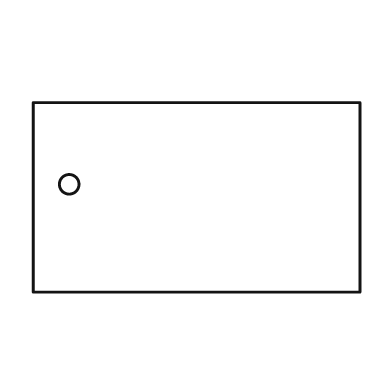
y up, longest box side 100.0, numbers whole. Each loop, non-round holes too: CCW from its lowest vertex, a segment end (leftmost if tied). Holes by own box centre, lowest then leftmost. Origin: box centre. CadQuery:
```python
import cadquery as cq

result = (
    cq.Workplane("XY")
    .moveTo(-50.0, -29.0)
    .lineTo(50.0, -29.0)
    .lineTo(50.0, 29.0)
    .lineTo(-50.0, 29.0)
    .close()
    .moveTo(-39.0, 4.0)
    .circle(3.0)
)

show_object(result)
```